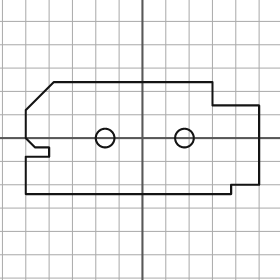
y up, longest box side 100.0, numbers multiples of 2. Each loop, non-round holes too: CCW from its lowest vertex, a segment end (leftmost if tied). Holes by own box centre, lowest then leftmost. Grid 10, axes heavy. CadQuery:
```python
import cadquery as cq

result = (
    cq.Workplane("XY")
    .moveTo(-50.0, -24.0)
    .lineTo(38.0, -24.0)
    .lineTo(38.0, -20.0)
    .lineTo(50.0, -20.0)
    .lineTo(50.0, 14.0)
    .lineTo(30.0, 14.0)
    .lineTo(30.0, 24.0)
    .lineTo(-38.0, 24.0)
    .lineTo(-50.0, 12.0)
    .lineTo(-50.0, 0.0)
    .lineTo(-46.0, -4.0)
    .lineTo(-40.0, -4.0)
    .lineTo(-40.0, -8.0)
    .lineTo(-50.0, -8.0)
    .close()
    .moveTo(-16.0, 0.0)
    .circle(4.0)
    .moveTo(18.0, 0.0)
    .circle(4.0)
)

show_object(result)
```